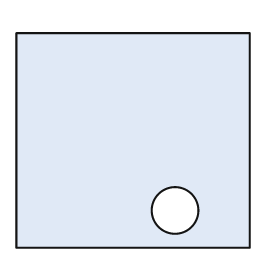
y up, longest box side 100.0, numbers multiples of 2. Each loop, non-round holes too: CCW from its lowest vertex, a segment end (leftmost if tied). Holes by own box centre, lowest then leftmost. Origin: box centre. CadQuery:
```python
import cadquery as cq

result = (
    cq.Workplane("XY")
    .moveTo(-50.0, -46.0)
    .lineTo(50.0, -46.0)
    .lineTo(50.0, 46.0)
    .lineTo(-50.0, 46.0)
    .close()
    .moveTo(18.0, -30.0)
    .circle(10.0)
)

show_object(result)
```